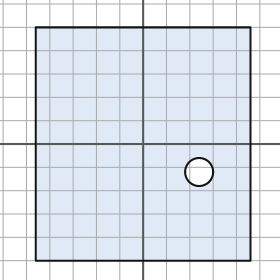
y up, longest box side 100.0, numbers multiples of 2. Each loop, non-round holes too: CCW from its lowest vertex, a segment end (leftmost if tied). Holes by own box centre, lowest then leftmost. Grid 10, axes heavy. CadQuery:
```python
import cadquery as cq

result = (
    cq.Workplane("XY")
    .moveTo(-46.0, -50.0)
    .lineTo(46.0, -50.0)
    .lineTo(46.0, 50.0)
    .lineTo(-46.0, 50.0)
    .close()
    .moveTo(24.0, -12.0)
    .circle(6.0)
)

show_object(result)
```